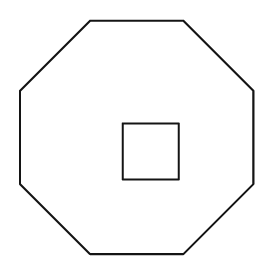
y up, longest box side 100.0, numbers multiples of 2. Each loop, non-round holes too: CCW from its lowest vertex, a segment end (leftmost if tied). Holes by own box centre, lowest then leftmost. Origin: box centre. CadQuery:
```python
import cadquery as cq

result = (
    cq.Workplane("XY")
    .moveTo(-20.0, -50.0)
    .lineTo(20.0, -50.0)
    .lineTo(50.0, -20.0)
    .lineTo(50.0, 20.0)
    .lineTo(20.0, 50.0)
    .lineTo(-20.0, 50.0)
    .lineTo(-50.0, 20.0)
    .lineTo(-50.0, -20.0)
    .close()
    .moveTo(-6.0, -18.0)
    .lineTo(18.0, -18.0)
    .lineTo(18.0, 6.0)
    .lineTo(-6.0, 6.0)
    .close()
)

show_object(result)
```